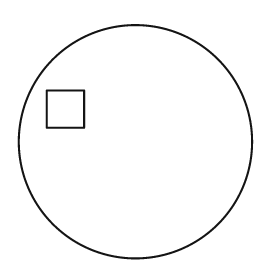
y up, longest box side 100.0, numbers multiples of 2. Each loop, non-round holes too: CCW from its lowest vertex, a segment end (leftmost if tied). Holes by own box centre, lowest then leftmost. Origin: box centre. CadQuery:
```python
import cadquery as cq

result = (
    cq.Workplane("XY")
    .moveTo(0.0, 0.0)
    .circle(50.0)
    .moveTo(-38.0, 6.0)
    .lineTo(-22.0, 6.0)
    .lineTo(-22.0, 22.0)
    .lineTo(-38.0, 22.0)
    .close()
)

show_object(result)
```